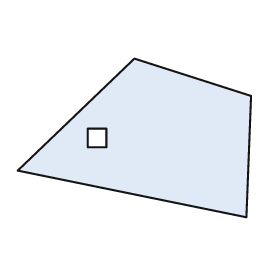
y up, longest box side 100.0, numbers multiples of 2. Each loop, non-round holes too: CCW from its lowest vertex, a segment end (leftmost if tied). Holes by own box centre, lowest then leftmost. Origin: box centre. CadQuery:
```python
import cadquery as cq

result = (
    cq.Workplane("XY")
    .moveTo(48.0, -34.0)
    .lineTo(50.0, 18.0)
    .lineTo(0.0, 34.0)
    .lineTo(-50.0, -14.0)
    .close()
    .moveTo(-20.0, -4.0)
    .lineTo(-12.0, -4.0)
    .lineTo(-12.0, 4.0)
    .lineTo(-20.0, 4.0)
    .close()
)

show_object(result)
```